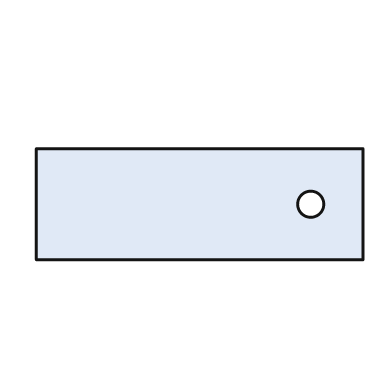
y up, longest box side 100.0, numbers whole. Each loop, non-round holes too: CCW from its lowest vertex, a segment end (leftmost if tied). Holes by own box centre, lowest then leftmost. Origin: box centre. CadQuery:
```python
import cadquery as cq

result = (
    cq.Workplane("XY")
    .moveTo(-50.0, -17.0)
    .lineTo(50.0, -17.0)
    .lineTo(50.0, 17.0)
    .lineTo(-50.0, 17.0)
    .close()
    .moveTo(34.0, 0.0)
    .circle(4.0)
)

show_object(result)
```